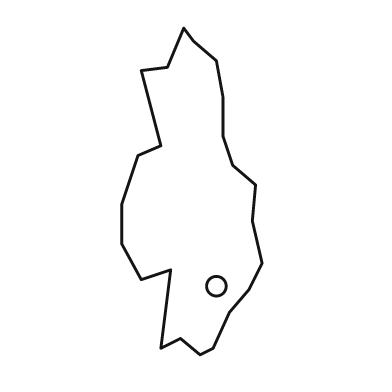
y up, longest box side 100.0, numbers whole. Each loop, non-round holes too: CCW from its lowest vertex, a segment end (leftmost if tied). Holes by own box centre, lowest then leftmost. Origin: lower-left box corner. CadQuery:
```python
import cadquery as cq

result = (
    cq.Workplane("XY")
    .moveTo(24.0, 0.0)
    .lineTo(28.0, 2.0)
    .lineTo(33.0, 13.0)
    .lineTo(39.0, 20.0)
    .lineTo(43.0, 28.0)
    .lineTo(40.0, 41.0)
    .lineTo(41.0, 52.0)
    .lineTo(34.0, 58.0)
    .lineTo(31.0, 67.0)
    .lineTo(31.0, 79.0)
    .lineTo(29.0, 90.0)
    .lineTo(22.0, 96.0)
    .lineTo(19.0, 100.0)
    .lineTo(14.0, 88.0)
    .lineTo(6.0, 87.0)
    .lineTo(12.0, 64.0)
    .lineTo(5.0, 61.0)
    .lineTo(0.0, 46.0)
    .lineTo(0.0, 34.0)
    .lineTo(6.0, 23.0)
    .lineTo(15.0, 26.0)
    .lineTo(12.0, 2.0)
    .lineTo(18.0, 5.0)
    .close()
    .moveTo(29.0, 21.0)
    .circle(3.0)
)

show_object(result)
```